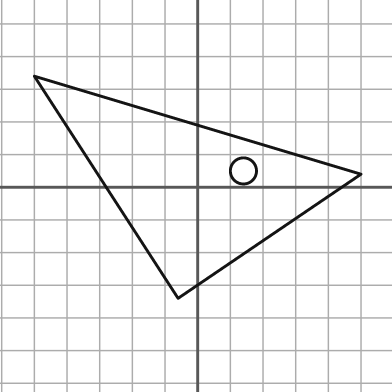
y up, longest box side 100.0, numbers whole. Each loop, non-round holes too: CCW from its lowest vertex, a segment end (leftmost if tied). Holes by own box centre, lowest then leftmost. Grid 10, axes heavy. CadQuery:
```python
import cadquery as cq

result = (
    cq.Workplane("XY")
    .moveTo(-6.0, -34.0)
    .lineTo(50.0, 4.0)
    .lineTo(-50.0, 34.0)
    .close()
    .moveTo(14.0, 5.0)
    .circle(4.0)
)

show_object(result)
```